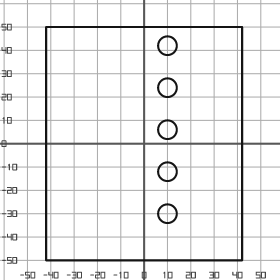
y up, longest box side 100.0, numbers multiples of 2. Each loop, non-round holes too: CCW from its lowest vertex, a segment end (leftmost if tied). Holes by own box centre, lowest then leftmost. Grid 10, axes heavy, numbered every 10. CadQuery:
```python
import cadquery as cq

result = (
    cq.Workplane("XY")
    .moveTo(-42.0, -50.0)
    .lineTo(42.0, -50.0)
    .lineTo(42.0, 50.0)
    .lineTo(-42.0, 50.0)
    .close()
    .moveTo(10.0, -30.0)
    .circle(4.0)
    .moveTo(10.0, -12.0)
    .circle(4.0)
    .moveTo(10.0, 6.0)
    .circle(4.0)
    .moveTo(10.0, 24.0)
    .circle(4.0)
    .moveTo(10.0, 42.0)
    .circle(4.0)
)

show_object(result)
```